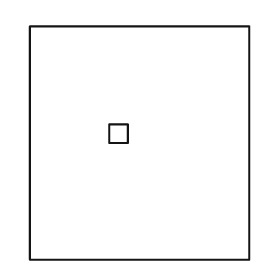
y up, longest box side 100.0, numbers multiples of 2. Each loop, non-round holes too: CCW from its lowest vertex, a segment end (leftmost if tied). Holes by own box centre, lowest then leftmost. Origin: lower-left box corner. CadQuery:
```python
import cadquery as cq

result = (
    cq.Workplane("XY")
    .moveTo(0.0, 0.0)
    .lineTo(94.0, 0.0)
    .lineTo(94.0, 100.0)
    .lineTo(0.0, 100.0)
    .close()
    .moveTo(34.0, 50.0)
    .lineTo(42.0, 50.0)
    .lineTo(42.0, 58.0)
    .lineTo(34.0, 58.0)
    .close()
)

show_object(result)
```